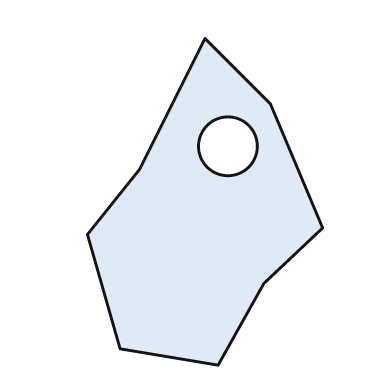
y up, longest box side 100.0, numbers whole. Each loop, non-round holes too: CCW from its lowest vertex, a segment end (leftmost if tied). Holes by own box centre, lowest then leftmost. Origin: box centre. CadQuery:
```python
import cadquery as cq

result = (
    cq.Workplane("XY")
    .moveTo(4.0, -50.0)
    .lineTo(18.0, -25.0)
    .lineTo(36.0, -8.0)
    .lineTo(20.0, 30.0)
    .lineTo(0.0, 50.0)
    .lineTo(-20.0, 10.0)
    .lineTo(-36.0, -10.0)
    .lineTo(-26.0, -45.0)
    .close()
    .moveTo(7.0, 17.0)
    .circle(9.0)
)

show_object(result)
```